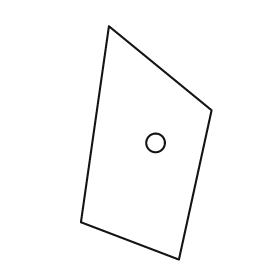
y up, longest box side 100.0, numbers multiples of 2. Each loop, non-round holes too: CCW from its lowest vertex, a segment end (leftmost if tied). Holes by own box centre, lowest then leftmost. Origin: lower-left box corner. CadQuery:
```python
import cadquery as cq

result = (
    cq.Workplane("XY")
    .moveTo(42.0, 0.0)
    .lineTo(56.0, 64.0)
    .lineTo(12.0, 100.0)
    .lineTo(0.0, 16.0)
    .close()
    .moveTo(32.0, 50.0)
    .circle(4.0)
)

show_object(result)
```